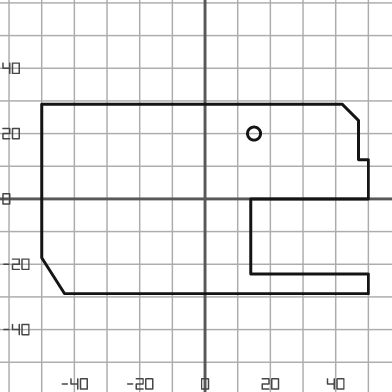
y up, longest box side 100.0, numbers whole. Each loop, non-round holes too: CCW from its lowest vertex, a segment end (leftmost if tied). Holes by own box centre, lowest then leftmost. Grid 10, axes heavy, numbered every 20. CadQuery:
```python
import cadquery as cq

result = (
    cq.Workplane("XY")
    .moveTo(-43.0, -29.0)
    .lineTo(50.0, -29.0)
    .lineTo(50.0, -23.0)
    .lineTo(14.0, -23.0)
    .lineTo(14.0, 0.0)
    .lineTo(50.0, 0.0)
    .lineTo(50.0, 12.0)
    .lineTo(47.0, 12.0)
    .lineTo(47.0, 24.0)
    .lineTo(42.0, 29.0)
    .lineTo(-50.0, 29.0)
    .lineTo(-50.0, -18.0)
    .close()
    .moveTo(15.0, 20.0)
    .circle(2.0)
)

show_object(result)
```